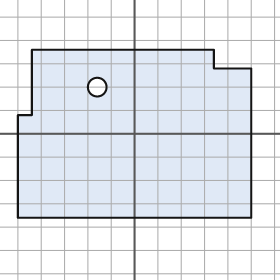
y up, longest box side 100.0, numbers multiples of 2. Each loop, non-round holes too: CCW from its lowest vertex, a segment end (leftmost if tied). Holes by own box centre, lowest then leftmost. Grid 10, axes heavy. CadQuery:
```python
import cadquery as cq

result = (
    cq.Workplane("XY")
    .moveTo(-50.0, -36.0)
    .lineTo(50.0, -36.0)
    .lineTo(50.0, 28.0)
    .lineTo(34.0, 28.0)
    .lineTo(34.0, 36.0)
    .lineTo(-44.0, 36.0)
    .lineTo(-44.0, 8.0)
    .lineTo(-50.0, 8.0)
    .close()
    .moveTo(-16.0, 20.0)
    .circle(4.0)
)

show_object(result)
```